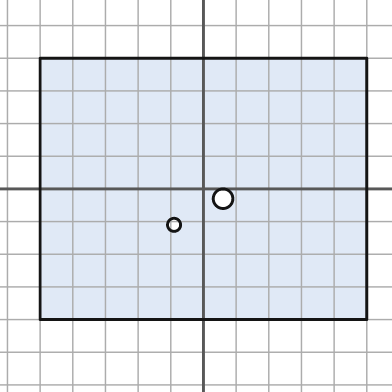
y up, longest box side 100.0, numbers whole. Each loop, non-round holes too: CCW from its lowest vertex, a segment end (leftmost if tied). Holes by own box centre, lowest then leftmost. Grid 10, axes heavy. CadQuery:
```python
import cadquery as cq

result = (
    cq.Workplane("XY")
    .moveTo(-50.0, -40.0)
    .lineTo(50.0, -40.0)
    .lineTo(50.0, 40.0)
    .lineTo(-50.0, 40.0)
    .close()
    .moveTo(-9.0, -11.0)
    .circle(2.0)
    .moveTo(6.0, -3.0)
    .circle(3.0)
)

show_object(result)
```